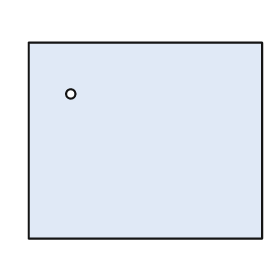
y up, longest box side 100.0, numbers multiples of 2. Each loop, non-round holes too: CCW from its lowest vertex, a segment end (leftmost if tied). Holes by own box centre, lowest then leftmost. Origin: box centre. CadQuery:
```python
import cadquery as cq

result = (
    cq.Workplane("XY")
    .moveTo(-50.0, -42.0)
    .lineTo(50.0, -42.0)
    .lineTo(50.0, 42.0)
    .lineTo(-50.0, 42.0)
    .close()
    .moveTo(-32.0, 20.0)
    .circle(2.0)
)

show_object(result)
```